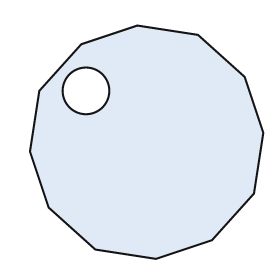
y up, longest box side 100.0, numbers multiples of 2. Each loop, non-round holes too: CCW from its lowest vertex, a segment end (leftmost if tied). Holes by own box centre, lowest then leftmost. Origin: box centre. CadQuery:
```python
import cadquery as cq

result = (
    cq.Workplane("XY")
    .moveTo(4.0, -50.0)
    .lineTo(28.0, -42.0)
    .lineTo(46.0, -22.0)
    .lineTo(50.0, 4.0)
    .lineTo(42.0, 28.0)
    .lineTo(22.0, 46.0)
    .lineTo(-4.0, 50.0)
    .lineTo(-28.0, 42.0)
    .lineTo(-46.0, 22.0)
    .lineTo(-50.0, -4.0)
    .lineTo(-42.0, -28.0)
    .lineTo(-22.0, -46.0)
    .close()
    .moveTo(-26.0, 22.0)
    .circle(10.0)
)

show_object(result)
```